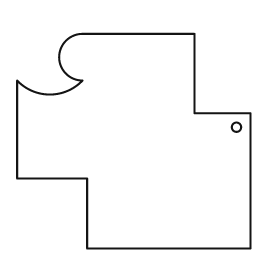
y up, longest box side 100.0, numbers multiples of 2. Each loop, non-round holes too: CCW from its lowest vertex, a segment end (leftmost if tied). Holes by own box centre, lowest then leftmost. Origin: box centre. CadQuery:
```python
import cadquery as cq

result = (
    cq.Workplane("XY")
    .moveTo(-20.0, -46.0)
    .lineTo(50.0, -46.0)
    .lineTo(50.0, 12.0)
    .lineTo(26.0, 12.0)
    .lineTo(26.0, 46.0)
    .lineTo(-22.0, 46.0)
    .threePointArc((-32.0, 36.0), (-22.0, 26.0))
    .threePointArc((-36.0, 20.0), (-50.0, 26.0))
    .lineTo(-50.0, -16.0)
    .lineTo(-20.0, -16.0)
    .close()
    .moveTo(44.0, 6.0)
    .circle(2.0)
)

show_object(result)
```